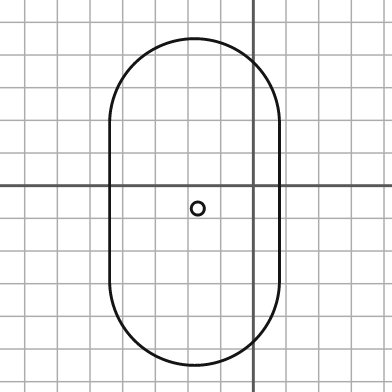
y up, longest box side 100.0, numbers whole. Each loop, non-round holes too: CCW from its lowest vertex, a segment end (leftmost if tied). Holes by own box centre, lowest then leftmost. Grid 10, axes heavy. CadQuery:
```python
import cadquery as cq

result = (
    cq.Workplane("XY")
    .moveTo(-44.0, -29.0)
    .threePointArc((-18.0, -55.0), (8.0, -29.0))
    .lineTo(8.0, 19.0)
    .threePointArc((-18.0, 45.0), (-44.0, 19.0))
    .close()
    .moveTo(-17.0, -7.0)
    .circle(2.0)
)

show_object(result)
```